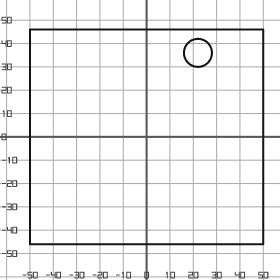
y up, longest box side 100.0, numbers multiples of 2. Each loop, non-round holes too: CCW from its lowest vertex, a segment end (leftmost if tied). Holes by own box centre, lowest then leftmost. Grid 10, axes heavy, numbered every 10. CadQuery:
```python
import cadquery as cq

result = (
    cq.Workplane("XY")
    .moveTo(-50.0, -46.0)
    .lineTo(50.0, -46.0)
    .lineTo(50.0, 46.0)
    .lineTo(-50.0, 46.0)
    .close()
    .moveTo(22.0, 36.0)
    .circle(6.0)
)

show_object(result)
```